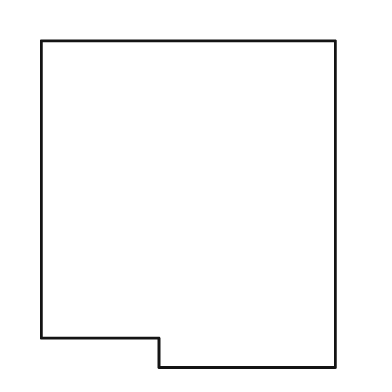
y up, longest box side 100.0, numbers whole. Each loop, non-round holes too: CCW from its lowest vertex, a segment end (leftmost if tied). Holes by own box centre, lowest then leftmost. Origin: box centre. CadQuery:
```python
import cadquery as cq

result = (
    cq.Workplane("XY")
    .moveTo(-9.0, -50.0)
    .lineTo(45.0, -50.0)
    .lineTo(45.0, 50.0)
    .lineTo(-45.0, 50.0)
    .lineTo(-45.0, -41.0)
    .lineTo(-9.0, -41.0)
    .close()
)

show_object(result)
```